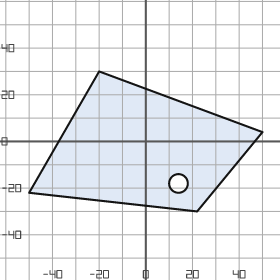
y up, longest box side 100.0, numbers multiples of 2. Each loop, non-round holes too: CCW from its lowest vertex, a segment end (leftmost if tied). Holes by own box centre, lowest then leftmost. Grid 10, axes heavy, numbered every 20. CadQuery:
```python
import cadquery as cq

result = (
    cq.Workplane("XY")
    .moveTo(22.0, -30.0)
    .lineTo(50.0, 4.0)
    .lineTo(-20.0, 30.0)
    .lineTo(-50.0, -22.0)
    .close()
    .moveTo(14.0, -18.0)
    .circle(4.0)
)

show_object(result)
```